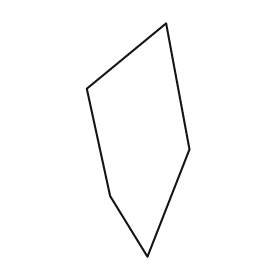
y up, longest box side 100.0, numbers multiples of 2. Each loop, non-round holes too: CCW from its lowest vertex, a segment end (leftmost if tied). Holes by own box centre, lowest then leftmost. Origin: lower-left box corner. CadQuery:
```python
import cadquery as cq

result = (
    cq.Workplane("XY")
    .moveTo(26.0, 0.0)
    .lineTo(44.0, 46.0)
    .lineTo(34.0, 100.0)
    .lineTo(0.0, 72.0)
    .lineTo(10.0, 26.0)
    .close()
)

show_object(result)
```